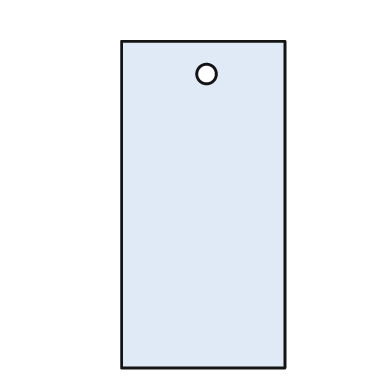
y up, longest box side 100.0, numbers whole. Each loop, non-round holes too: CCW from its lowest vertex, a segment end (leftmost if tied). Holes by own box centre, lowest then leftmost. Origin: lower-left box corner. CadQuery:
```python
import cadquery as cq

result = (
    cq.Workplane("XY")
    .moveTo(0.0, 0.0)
    .lineTo(50.0, 0.0)
    .lineTo(50.0, 100.0)
    .lineTo(0.0, 100.0)
    .close()
    .moveTo(26.0, 90.0)
    .circle(3.0)
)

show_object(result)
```